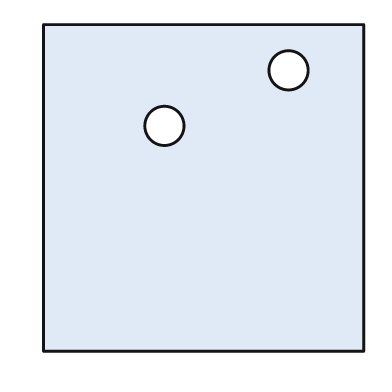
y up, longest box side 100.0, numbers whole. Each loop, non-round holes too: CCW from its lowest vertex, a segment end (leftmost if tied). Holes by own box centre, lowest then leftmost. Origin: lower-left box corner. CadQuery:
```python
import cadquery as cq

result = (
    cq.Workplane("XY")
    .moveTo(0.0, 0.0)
    .lineTo(98.0, 0.0)
    .lineTo(98.0, 100.0)
    .lineTo(0.0, 100.0)
    .close()
    .moveTo(37.0, 69.0)
    .circle(6.0)
    .moveTo(75.0, 86.0)
    .circle(6.0)
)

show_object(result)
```